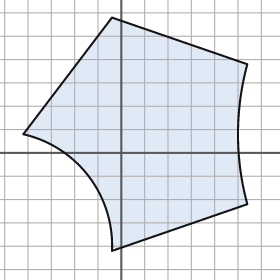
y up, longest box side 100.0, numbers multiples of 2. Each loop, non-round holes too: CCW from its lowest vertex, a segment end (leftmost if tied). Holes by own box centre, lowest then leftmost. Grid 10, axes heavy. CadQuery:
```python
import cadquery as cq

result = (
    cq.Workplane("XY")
    .moveTo(-4.0, -42.0)
    .lineTo(54.0, -22.0)
    .threePointArc((50.0, 8.0), (54.0, 38.0))
    .lineTo(-4.0, 58.0)
    .lineTo(-42.0, 8.0)
    .threePointArc((-14.0, -10.0), (-4.0, -42.0))
    .close()
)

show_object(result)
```